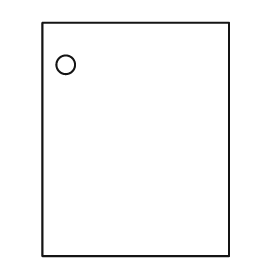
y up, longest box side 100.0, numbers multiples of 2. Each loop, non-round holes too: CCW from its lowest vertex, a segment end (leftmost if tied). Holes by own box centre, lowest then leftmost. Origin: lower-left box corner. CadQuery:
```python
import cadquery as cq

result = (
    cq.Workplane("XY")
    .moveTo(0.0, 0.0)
    .lineTo(80.0, 0.0)
    .lineTo(80.0, 100.0)
    .lineTo(0.0, 100.0)
    .close()
    .moveTo(10.0, 82.0)
    .circle(4.0)
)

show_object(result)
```